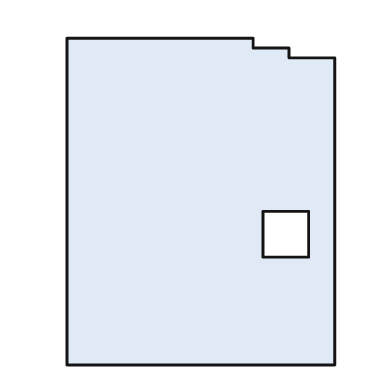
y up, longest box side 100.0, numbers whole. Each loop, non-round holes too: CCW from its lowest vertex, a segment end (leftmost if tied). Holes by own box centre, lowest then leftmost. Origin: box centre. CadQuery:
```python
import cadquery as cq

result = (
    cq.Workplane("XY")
    .moveTo(-41.0, -50.0)
    .lineTo(41.0, -50.0)
    .lineTo(41.0, 44.0)
    .lineTo(27.0, 44.0)
    .lineTo(27.0, 47.0)
    .lineTo(16.0, 47.0)
    .lineTo(16.0, 50.0)
    .lineTo(-41.0, 50.0)
    .close()
    .moveTo(19.0, -17.0)
    .lineTo(33.0, -17.0)
    .lineTo(33.0, -3.0)
    .lineTo(19.0, -3.0)
    .close()
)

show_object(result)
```